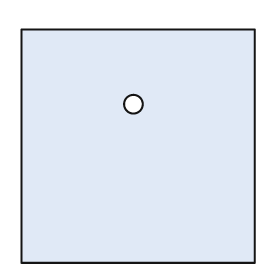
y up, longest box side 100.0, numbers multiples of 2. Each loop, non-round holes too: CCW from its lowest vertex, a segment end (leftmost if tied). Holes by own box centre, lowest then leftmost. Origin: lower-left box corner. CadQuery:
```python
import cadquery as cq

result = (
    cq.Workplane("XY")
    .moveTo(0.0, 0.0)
    .lineTo(100.0, 0.0)
    .lineTo(100.0, 100.0)
    .lineTo(0.0, 100.0)
    .close()
    .moveTo(48.0, 68.0)
    .circle(4.0)
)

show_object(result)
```